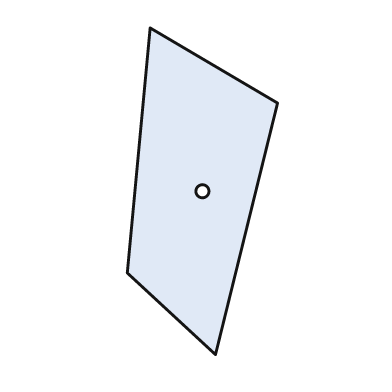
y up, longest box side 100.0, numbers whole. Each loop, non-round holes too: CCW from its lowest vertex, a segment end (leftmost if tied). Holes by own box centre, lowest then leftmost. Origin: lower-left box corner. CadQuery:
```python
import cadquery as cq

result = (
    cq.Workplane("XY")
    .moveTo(27.0, 0.0)
    .lineTo(46.0, 77.0)
    .lineTo(7.0, 100.0)
    .lineTo(0.0, 25.0)
    .close()
    .moveTo(23.0, 50.0)
    .circle(2.0)
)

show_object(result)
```